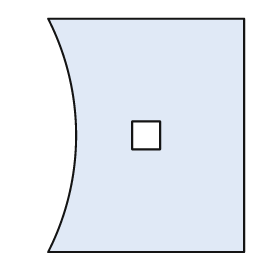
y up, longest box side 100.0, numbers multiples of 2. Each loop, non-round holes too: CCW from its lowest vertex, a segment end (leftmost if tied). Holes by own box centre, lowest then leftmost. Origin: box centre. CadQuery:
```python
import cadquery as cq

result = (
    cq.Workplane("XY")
    .moveTo(-42.0, -50.0)
    .lineTo(42.0, -50.0)
    .lineTo(42.0, 50.0)
    .lineTo(-42.0, 50.0)
    .threePointArc((-30.0, 0.0), (-42.0, -50.0))
    .close()
    .moveTo(-6.0, -6.0)
    .lineTo(6.0, -6.0)
    .lineTo(6.0, 6.0)
    .lineTo(-6.0, 6.0)
    .close()
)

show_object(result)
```